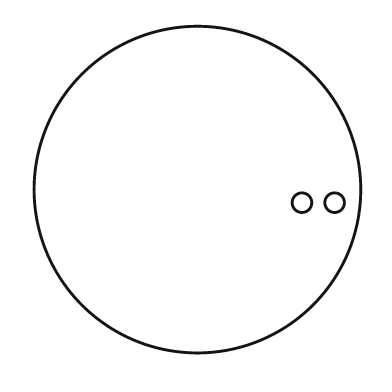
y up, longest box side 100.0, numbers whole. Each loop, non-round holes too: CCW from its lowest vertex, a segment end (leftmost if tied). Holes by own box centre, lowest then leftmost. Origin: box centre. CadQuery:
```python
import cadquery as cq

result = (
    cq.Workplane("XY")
    .moveTo(0.0, 0.0)
    .circle(50.0)
    .moveTo(32.0, -4.0)
    .circle(3.0)
    .moveTo(42.0, -4.0)
    .circle(3.0)
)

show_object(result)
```